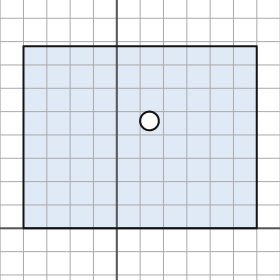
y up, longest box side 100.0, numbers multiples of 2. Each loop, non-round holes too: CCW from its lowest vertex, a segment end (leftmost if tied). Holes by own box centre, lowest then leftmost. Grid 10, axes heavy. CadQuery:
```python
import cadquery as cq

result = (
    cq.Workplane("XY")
    .moveTo(-40.0, 0.0)
    .lineTo(60.0, 0.0)
    .lineTo(60.0, 78.0)
    .lineTo(-40.0, 78.0)
    .close()
    .moveTo(14.0, 46.0)
    .circle(4.0)
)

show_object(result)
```